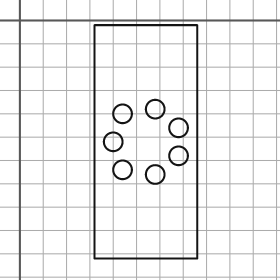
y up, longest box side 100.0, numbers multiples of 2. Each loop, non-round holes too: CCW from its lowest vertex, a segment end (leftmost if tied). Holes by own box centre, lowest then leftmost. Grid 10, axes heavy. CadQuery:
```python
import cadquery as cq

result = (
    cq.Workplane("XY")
    .moveTo(32.0, -102.0)
    .lineTo(76.0, -102.0)
    .lineTo(76.0, -2.0)
    .lineTo(32.0, -2.0)
    .close()
    .moveTo(58.0, -66.0)
    .circle(4.0)
    .moveTo(44.0, -64.0)
    .circle(4.0)
    .moveTo(68.0, -58.0)
    .circle(4.0)
    .moveTo(40.0, -52.0)
    .circle(4.0)
    .moveTo(68.0, -46.0)
    .circle(4.0)
    .moveTo(44.0, -40.0)
    .circle(4.0)
    .moveTo(58.0, -38.0)
    .circle(4.0)
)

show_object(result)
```